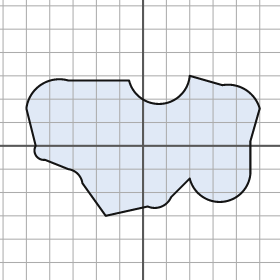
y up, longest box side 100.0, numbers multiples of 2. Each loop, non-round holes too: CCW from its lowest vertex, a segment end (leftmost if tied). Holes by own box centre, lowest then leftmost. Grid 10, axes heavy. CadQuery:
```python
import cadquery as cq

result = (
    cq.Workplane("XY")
    .moveTo(-16.0, -30.0)
    .lineTo(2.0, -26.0)
    .threePointArc((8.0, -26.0), (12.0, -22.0))
    .lineTo(20.0, -14.0)
    .threePointArc((34.0, -24.0), (46.0, -12.0))
    .lineTo(46.0, 2.0)
    .lineTo(50.0, 16.0)
    .threePointArc((44.0, 24.0), (34.0, 26.0))
    .lineTo(20.0, 30.0)
    .threePointArc((8.0, 18.0), (-6.0, 28.0))
    .lineTo(-32.0, 28.0)
    .threePointArc((-44.0, 26.0), (-50.0, 16.0))
    .lineTo(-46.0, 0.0)
    .threePointArc((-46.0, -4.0), (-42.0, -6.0))
    .lineTo(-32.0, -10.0)
    .threePointArc((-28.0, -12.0), (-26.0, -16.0))
    .close()
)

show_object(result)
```